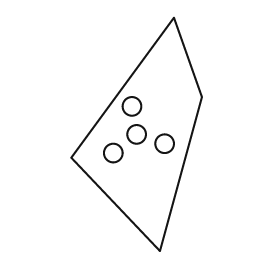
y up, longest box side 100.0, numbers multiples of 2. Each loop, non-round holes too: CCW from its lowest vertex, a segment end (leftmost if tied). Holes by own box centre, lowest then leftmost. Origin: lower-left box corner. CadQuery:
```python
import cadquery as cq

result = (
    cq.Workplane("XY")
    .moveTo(38.0, 0.0)
    .lineTo(56.0, 66.0)
    .lineTo(44.0, 100.0)
    .lineTo(0.0, 40.0)
    .close()
    .moveTo(18.0, 42.0)
    .circle(4.0)
    .moveTo(40.0, 46.0)
    .circle(4.0)
    .moveTo(28.0, 50.0)
    .circle(4.0)
    .moveTo(26.0, 62.0)
    .circle(4.0)
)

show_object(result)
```